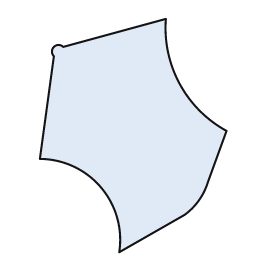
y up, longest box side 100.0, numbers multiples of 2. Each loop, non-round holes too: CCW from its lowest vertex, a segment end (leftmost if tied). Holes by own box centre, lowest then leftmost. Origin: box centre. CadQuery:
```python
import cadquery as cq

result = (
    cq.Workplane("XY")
    .moveTo(-6.0, -50.0)
    .lineTo(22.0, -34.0)
    .threePointArc((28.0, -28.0), (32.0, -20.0))
    .lineTo(40.0, 2.0)
    .threePointArc((20.0, 22.0), (14.0, 50.0))
    .lineTo(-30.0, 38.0)
    .threePointArc((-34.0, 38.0), (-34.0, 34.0))
    .lineTo(-40.0, -10.0)
    .threePointArc((-14.0, -22.0), (-6.0, -50.0))
    .close()
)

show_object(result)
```